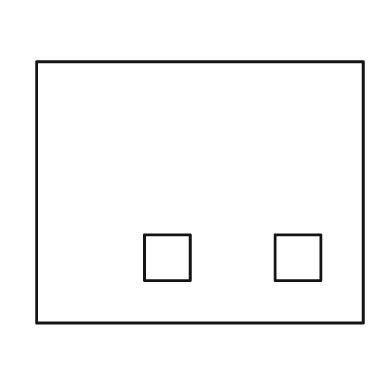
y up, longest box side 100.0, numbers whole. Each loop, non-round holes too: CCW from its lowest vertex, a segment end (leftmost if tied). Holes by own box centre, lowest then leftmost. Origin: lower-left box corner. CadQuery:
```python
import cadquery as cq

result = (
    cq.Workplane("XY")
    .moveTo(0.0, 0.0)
    .lineTo(100.0, 0.0)
    .lineTo(100.0, 80.0)
    .lineTo(0.0, 80.0)
    .close()
    .moveTo(33.0, 13.0)
    .lineTo(47.0, 13.0)
    .lineTo(47.0, 27.0)
    .lineTo(33.0, 27.0)
    .close()
    .moveTo(73.0, 13.0)
    .lineTo(87.0, 13.0)
    .lineTo(87.0, 27.0)
    .lineTo(73.0, 27.0)
    .close()
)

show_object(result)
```